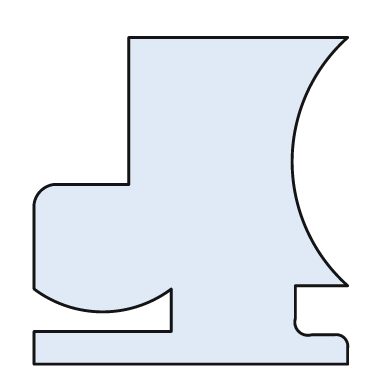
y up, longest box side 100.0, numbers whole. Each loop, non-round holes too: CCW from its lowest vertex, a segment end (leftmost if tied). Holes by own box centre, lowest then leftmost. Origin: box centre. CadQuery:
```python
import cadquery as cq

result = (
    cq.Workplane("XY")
    .moveTo(-48.0, -50.0)
    .lineTo(48.0, -50.0)
    .lineTo(48.0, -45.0)
    .threePointArc((47.0, -42.0), (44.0, -41.0))
    .lineTo(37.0, -41.0)
    .threePointArc((33.0, -40.0), (32.0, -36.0))
    .lineTo(32.0, -26.0)
    .lineTo(48.0, -26.0)
    .threePointArc((31.0, 12.0), (48.0, 50.0))
    .lineTo(-19.0, 50.0)
    .lineTo(-19.0, 5.0)
    .lineTo(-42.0, 5.0)
    .threePointArc((-46.0, 3.0), (-48.0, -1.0))
    .lineTo(-48.0, -27.0)
    .threePointArc((-27.0, -34.0), (-6.0, -27.0))
    .lineTo(-6.0, -40.0)
    .lineTo(-48.0, -40.0)
    .close()
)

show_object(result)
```